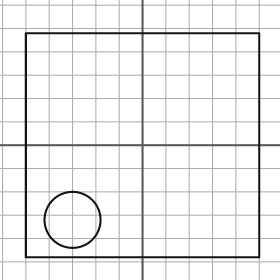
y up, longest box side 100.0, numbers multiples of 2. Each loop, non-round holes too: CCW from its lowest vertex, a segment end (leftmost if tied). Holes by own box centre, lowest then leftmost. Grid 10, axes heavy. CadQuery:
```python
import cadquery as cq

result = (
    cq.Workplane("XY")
    .moveTo(-50.0, -48.0)
    .lineTo(50.0, -48.0)
    .lineTo(50.0, 48.0)
    .lineTo(-50.0, 48.0)
    .close()
    .moveTo(-30.0, -32.0)
    .circle(12.0)
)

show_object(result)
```